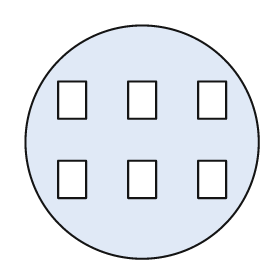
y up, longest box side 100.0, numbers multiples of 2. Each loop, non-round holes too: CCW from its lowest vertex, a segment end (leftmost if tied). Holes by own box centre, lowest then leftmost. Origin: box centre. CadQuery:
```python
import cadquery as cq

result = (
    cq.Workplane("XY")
    .moveTo(0.0, 0.0)
    .circle(50.0)
    .moveTo(-36.0, -24.0)
    .lineTo(-24.0, -24.0)
    .lineTo(-24.0, -8.0)
    .lineTo(-36.0, -8.0)
    .close()
    .moveTo(-6.0, -24.0)
    .lineTo(6.0, -24.0)
    .lineTo(6.0, -8.0)
    .lineTo(-6.0, -8.0)
    .close()
    .moveTo(24.0, -24.0)
    .lineTo(36.0, -24.0)
    .lineTo(36.0, -8.0)
    .lineTo(24.0, -8.0)
    .close()
    .moveTo(-36.0, 10.0)
    .lineTo(-24.0, 10.0)
    .lineTo(-24.0, 26.0)
    .lineTo(-36.0, 26.0)
    .close()
    .moveTo(-6.0, 10.0)
    .lineTo(6.0, 10.0)
    .lineTo(6.0, 26.0)
    .lineTo(-6.0, 26.0)
    .close()
    .moveTo(24.0, 10.0)
    .lineTo(36.0, 10.0)
    .lineTo(36.0, 26.0)
    .lineTo(24.0, 26.0)
    .close()
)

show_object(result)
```